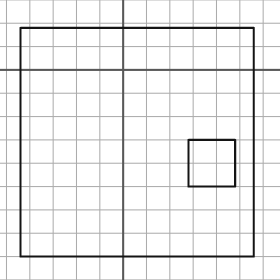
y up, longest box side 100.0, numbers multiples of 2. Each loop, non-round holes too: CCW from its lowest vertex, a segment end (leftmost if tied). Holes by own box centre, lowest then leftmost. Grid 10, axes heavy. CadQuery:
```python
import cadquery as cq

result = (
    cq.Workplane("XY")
    .moveTo(-44.0, -80.0)
    .lineTo(56.0, -80.0)
    .lineTo(56.0, 18.0)
    .lineTo(-44.0, 18.0)
    .close()
    .moveTo(28.0, -50.0)
    .lineTo(48.0, -50.0)
    .lineTo(48.0, -30.0)
    .lineTo(28.0, -30.0)
    .close()
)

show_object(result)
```